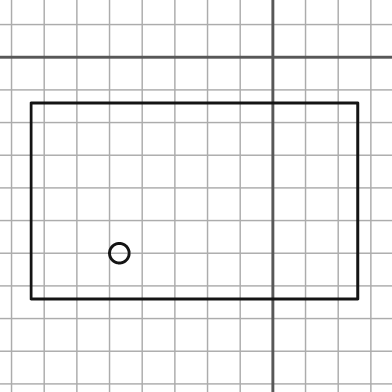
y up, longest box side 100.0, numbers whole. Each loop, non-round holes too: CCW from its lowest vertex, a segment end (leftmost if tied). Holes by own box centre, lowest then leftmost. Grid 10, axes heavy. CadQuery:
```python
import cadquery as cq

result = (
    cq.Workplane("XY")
    .moveTo(-74.0, -74.0)
    .lineTo(26.0, -74.0)
    .lineTo(26.0, -14.0)
    .lineTo(-74.0, -14.0)
    .close()
    .moveTo(-47.0, -60.0)
    .circle(3.0)
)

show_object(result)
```